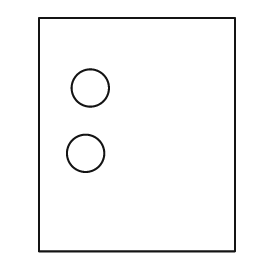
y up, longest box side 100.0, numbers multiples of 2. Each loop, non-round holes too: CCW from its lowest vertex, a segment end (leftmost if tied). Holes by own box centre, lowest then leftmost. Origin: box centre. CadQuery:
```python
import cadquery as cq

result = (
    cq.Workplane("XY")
    .moveTo(-42.0, -50.0)
    .lineTo(42.0, -50.0)
    .lineTo(42.0, 50.0)
    .lineTo(-42.0, 50.0)
    .close()
    .moveTo(-22.0, -8.0)
    .circle(8.0)
    .moveTo(-20.0, 20.0)
    .circle(8.0)
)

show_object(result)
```